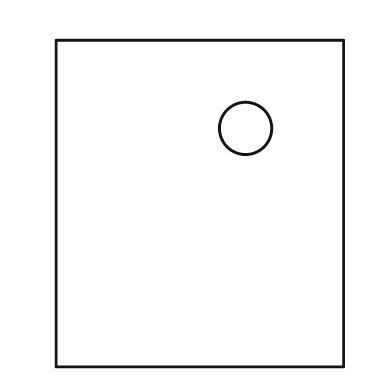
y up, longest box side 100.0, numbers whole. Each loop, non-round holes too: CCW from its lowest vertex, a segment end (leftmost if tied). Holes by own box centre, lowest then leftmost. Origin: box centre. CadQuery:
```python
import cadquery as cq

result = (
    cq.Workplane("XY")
    .moveTo(-44.0, -50.0)
    .lineTo(44.0, -50.0)
    .lineTo(44.0, 50.0)
    .lineTo(-44.0, 50.0)
    .close()
    .moveTo(14.0, 23.0)
    .circle(8.0)
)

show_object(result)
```